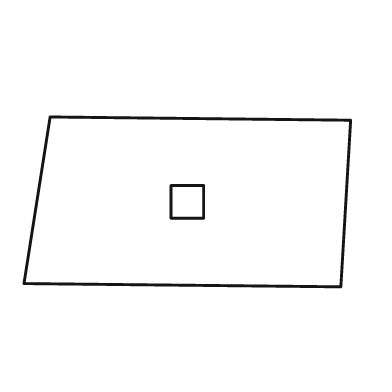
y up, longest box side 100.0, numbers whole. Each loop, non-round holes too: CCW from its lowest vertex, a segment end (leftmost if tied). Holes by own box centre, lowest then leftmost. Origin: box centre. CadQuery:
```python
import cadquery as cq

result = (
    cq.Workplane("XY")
    .moveTo(47.0, -26.0)
    .lineTo(50.0, 25.0)
    .lineTo(-42.0, 26.0)
    .lineTo(-50.0, -25.0)
    .close()
    .moveTo(-5.0, -5.0)
    .lineTo(5.0, -5.0)
    .lineTo(5.0, 5.0)
    .lineTo(-5.0, 5.0)
    .close()
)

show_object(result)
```